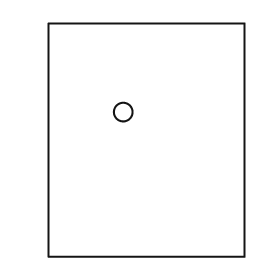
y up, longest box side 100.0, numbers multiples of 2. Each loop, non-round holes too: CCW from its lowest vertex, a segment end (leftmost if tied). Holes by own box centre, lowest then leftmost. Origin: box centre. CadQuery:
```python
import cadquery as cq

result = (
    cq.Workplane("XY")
    .moveTo(-42.0, -50.0)
    .lineTo(42.0, -50.0)
    .lineTo(42.0, 50.0)
    .lineTo(-42.0, 50.0)
    .close()
    .moveTo(-10.0, 12.0)
    .circle(4.0)
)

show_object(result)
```